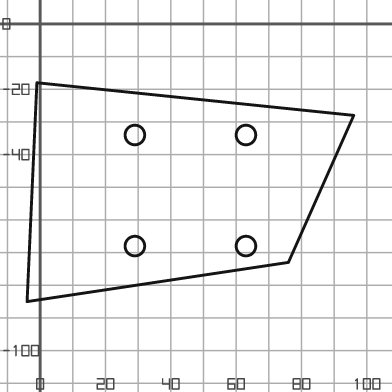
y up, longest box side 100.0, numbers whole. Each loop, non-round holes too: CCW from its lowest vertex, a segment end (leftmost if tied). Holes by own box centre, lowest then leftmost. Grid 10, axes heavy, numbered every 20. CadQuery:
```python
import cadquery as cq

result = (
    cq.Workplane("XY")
    .moveTo(-4.0, -85.0)
    .lineTo(76.0, -73.0)
    .lineTo(96.0, -28.0)
    .lineTo(-1.0, -18.0)
    .close()
    .moveTo(29.0, -68.0)
    .circle(3.0)
    .moveTo(63.0, -68.0)
    .circle(3.0)
    .moveTo(29.0, -34.0)
    .circle(3.0)
    .moveTo(63.0, -34.0)
    .circle(3.0)
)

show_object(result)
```